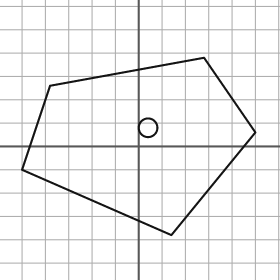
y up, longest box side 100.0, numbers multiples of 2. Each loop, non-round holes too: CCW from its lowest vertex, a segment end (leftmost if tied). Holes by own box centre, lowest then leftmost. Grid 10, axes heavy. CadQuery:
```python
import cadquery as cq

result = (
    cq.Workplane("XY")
    .moveTo(14.0, -38.0)
    .lineTo(50.0, 6.0)
    .lineTo(28.0, 38.0)
    .lineTo(-38.0, 26.0)
    .lineTo(-50.0, -10.0)
    .close()
    .moveTo(4.0, 8.0)
    .circle(4.0)
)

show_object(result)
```